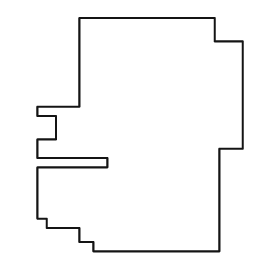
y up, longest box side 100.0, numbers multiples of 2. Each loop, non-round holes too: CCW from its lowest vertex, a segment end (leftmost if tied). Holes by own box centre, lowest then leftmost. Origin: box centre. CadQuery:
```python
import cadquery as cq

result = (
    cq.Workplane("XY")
    .moveTo(-20.0, -50.0)
    .lineTo(34.0, -50.0)
    .lineTo(34.0, -6.0)
    .lineTo(44.0, -6.0)
    .lineTo(44.0, 40.0)
    .lineTo(32.0, 40.0)
    .lineTo(32.0, 50.0)
    .lineTo(-26.0, 50.0)
    .lineTo(-26.0, 12.0)
    .lineTo(-44.0, 12.0)
    .lineTo(-44.0, 8.0)
    .lineTo(-36.0, 8.0)
    .lineTo(-36.0, -2.0)
    .lineTo(-44.0, -2.0)
    .lineTo(-44.0, -10.0)
    .lineTo(-14.0, -10.0)
    .lineTo(-14.0, -14.0)
    .lineTo(-44.0, -14.0)
    .lineTo(-44.0, -36.0)
    .lineTo(-40.0, -36.0)
    .lineTo(-40.0, -40.0)
    .lineTo(-26.0, -40.0)
    .lineTo(-26.0, -46.0)
    .lineTo(-20.0, -46.0)
    .close()
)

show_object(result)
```